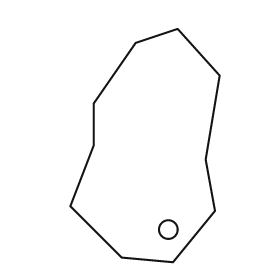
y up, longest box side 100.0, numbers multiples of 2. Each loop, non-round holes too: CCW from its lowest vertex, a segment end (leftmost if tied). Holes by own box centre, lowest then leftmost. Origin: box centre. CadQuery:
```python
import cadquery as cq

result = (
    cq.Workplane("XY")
    .moveTo(12.0, -50.0)
    .lineTo(30.0, -28.0)
    .lineTo(26.0, -6.0)
    .lineTo(32.0, 30.0)
    .lineTo(14.0, 50.0)
    .lineTo(-4.0, 44.0)
    .lineTo(-22.0, 18.0)
    .lineTo(-22.0, 0.0)
    .lineTo(-32.0, -26.0)
    .lineTo(-10.0, -48.0)
    .close()
    .moveTo(10.0, -36.0)
    .circle(4.0)
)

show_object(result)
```